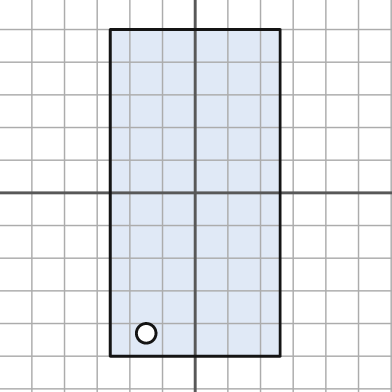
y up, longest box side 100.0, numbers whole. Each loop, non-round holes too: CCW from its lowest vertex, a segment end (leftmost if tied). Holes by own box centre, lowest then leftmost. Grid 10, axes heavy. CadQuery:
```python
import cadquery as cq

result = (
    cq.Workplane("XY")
    .moveTo(-26.0, -50.0)
    .lineTo(26.0, -50.0)
    .lineTo(26.0, 50.0)
    .lineTo(-26.0, 50.0)
    .close()
    .moveTo(-15.0, -43.0)
    .circle(3.0)
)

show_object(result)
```